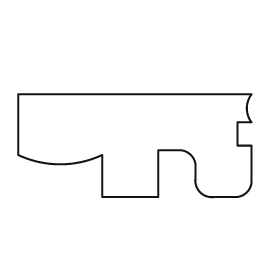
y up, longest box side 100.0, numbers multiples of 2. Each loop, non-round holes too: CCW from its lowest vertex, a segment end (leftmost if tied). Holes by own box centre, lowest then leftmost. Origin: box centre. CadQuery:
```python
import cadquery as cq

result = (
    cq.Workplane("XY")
    .moveTo(-14.0, -22.0)
    .lineTo(10.0, -22.0)
    .lineTo(10.0, -2.0)
    .lineTo(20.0, -2.0)
    .threePointArc((24.0, -4.0), (26.0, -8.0))
    .lineTo(26.0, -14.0)
    .threePointArc((28.0, -20.0), (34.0, -22.0))
    .lineTo(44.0, -22.0)
    .threePointArc((48.0, -20.0), (50.0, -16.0))
    .lineTo(50.0, 0.0)
    .lineTo(44.0, 0.0)
    .lineTo(44.0, 10.0)
    .lineTo(50.0, 10.0)
    .threePointArc((48.0, 16.0), (50.0, 22.0))
    .lineTo(-50.0, 22.0)
    .lineTo(-50.0, -4.0)
    .threePointArc((-32.0, -8.0), (-14.0, -4.0))
    .close()
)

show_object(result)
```